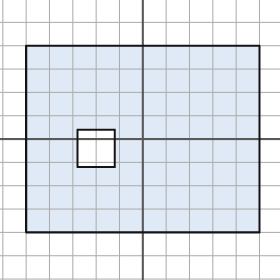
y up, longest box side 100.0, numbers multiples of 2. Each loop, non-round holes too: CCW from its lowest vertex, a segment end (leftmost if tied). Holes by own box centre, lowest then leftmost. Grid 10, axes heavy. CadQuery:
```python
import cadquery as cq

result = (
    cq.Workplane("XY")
    .moveTo(-50.0, -40.0)
    .lineTo(50.0, -40.0)
    .lineTo(50.0, 40.0)
    .lineTo(-50.0, 40.0)
    .close()
    .moveTo(-28.0, -12.0)
    .lineTo(-12.0, -12.0)
    .lineTo(-12.0, 4.0)
    .lineTo(-28.0, 4.0)
    .close()
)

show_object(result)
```